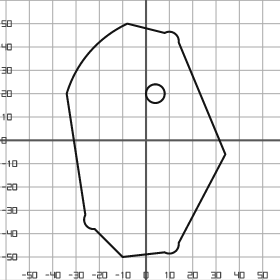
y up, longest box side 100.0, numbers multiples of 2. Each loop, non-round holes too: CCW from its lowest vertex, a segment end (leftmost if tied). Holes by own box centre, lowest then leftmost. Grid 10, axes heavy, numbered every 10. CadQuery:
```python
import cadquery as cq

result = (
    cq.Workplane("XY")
    .moveTo(-10.0, -50.0)
    .lineTo(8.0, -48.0)
    .threePointArc((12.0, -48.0), (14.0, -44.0))
    .lineTo(34.0, -6.0)
    .lineTo(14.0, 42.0)
    .threePointArc((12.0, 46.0), (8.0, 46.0))
    .lineTo(-8.0, 50.0)
    .threePointArc((-24.0, 38.0), (-34.0, 20.0))
    .lineTo(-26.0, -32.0)
    .threePointArc((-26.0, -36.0), (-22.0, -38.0))
    .close()
    .moveTo(4.0, 20.0)
    .circle(4.0)
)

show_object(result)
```